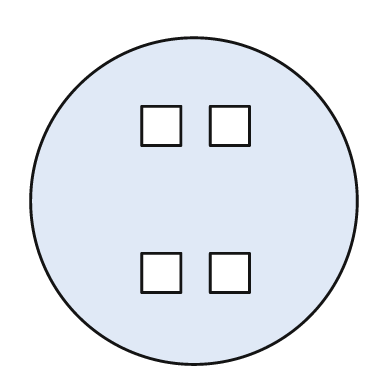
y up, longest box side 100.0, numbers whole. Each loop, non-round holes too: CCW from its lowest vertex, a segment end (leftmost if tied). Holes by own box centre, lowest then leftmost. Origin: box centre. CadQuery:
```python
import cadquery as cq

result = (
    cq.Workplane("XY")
    .moveTo(0.0, 0.0)
    .circle(50.0)
    .moveTo(-16.0, -28.0)
    .lineTo(-4.0, -28.0)
    .lineTo(-4.0, -16.0)
    .lineTo(-16.0, -16.0)
    .close()
    .moveTo(5.0, -28.0)
    .lineTo(17.0, -28.0)
    .lineTo(17.0, -16.0)
    .lineTo(5.0, -16.0)
    .close()
    .moveTo(-16.0, 17.0)
    .lineTo(-4.0, 17.0)
    .lineTo(-4.0, 29.0)
    .lineTo(-16.0, 29.0)
    .close()
    .moveTo(5.0, 17.0)
    .lineTo(17.0, 17.0)
    .lineTo(17.0, 29.0)
    .lineTo(5.0, 29.0)
    .close()
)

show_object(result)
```